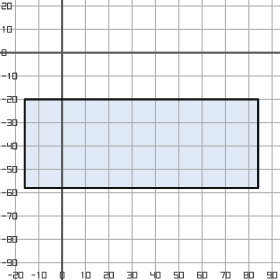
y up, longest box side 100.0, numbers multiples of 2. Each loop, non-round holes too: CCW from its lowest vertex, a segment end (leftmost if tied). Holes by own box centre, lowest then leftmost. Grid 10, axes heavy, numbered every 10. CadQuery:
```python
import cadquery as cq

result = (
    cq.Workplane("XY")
    .moveTo(-16.0, -58.0)
    .lineTo(84.0, -58.0)
    .lineTo(84.0, -20.0)
    .lineTo(-16.0, -20.0)
    .close()
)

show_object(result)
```